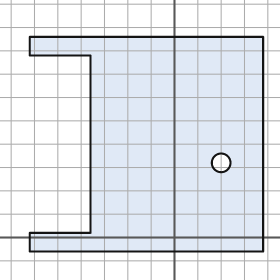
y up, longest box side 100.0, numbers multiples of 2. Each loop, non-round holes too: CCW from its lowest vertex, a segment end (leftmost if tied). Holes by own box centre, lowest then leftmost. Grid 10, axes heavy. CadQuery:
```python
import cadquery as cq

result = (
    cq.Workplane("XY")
    .moveTo(-62.0, -6.0)
    .lineTo(38.0, -6.0)
    .lineTo(38.0, 86.0)
    .lineTo(-62.0, 86.0)
    .lineTo(-62.0, 78.0)
    .lineTo(-36.0, 78.0)
    .lineTo(-36.0, 2.0)
    .lineTo(-62.0, 2.0)
    .close()
    .moveTo(20.0, 32.0)
    .circle(4.0)
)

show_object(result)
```